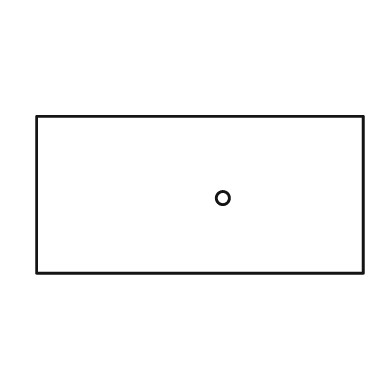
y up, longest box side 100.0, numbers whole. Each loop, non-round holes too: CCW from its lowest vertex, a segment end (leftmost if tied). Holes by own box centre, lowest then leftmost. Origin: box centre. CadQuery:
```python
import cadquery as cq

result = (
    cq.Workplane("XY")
    .moveTo(-50.0, -24.0)
    .lineTo(50.0, -24.0)
    .lineTo(50.0, 24.0)
    .lineTo(-50.0, 24.0)
    .close()
    .moveTo(7.0, -1.0)
    .circle(2.0)
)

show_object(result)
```